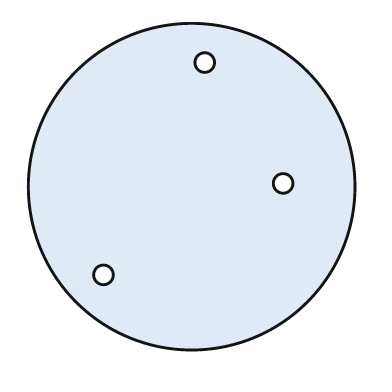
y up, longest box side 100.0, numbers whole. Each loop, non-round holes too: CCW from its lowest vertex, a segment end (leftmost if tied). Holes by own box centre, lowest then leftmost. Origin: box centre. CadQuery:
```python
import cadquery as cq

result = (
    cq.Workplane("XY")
    .moveTo(0.0, 0.0)
    .circle(50.0)
    .moveTo(-27.0, -27.0)
    .circle(3.0)
    .moveTo(28.0, 1.0)
    .circle(3.0)
    .moveTo(4.0, 38.0)
    .circle(3.0)
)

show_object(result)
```